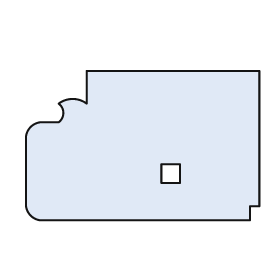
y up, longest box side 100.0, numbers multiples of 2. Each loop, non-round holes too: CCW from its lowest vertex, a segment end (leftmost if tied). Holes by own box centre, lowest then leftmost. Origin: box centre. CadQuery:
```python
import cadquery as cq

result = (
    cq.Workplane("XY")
    .moveTo(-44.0, -32.0)
    .lineTo(46.0, -32.0)
    .lineTo(46.0, -26.0)
    .lineTo(50.0, -26.0)
    .lineTo(50.0, 32.0)
    .lineTo(-24.0, 32.0)
    .lineTo(-24.0, 18.0)
    .threePointArc((-30.0, 20.0), (-36.0, 18.0))
    .threePointArc((-34.0, 14.0), (-36.0, 10.0))
    .lineTo(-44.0, 10.0)
    .threePointArc((-48.0, 8.0), (-50.0, 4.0))
    .lineTo(-50.0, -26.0)
    .threePointArc((-48.0, -30.0), (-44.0, -32.0))
    .close()
    .moveTo(8.0, -16.0)
    .lineTo(16.0, -16.0)
    .lineTo(16.0, -8.0)
    .lineTo(8.0, -8.0)
    .close()
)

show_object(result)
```